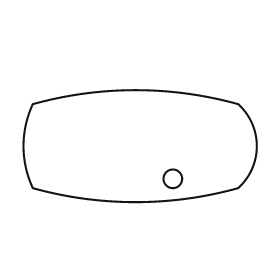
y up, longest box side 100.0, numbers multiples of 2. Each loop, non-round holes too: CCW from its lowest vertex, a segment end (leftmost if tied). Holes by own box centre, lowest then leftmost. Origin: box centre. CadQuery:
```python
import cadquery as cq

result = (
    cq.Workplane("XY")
    .moveTo(-46.0, -18.0)
    .threePointArc((-2.0, -24.0), (42.0, -18.0))
    .threePointArc((50.0, 0.0), (42.0, 18.0))
    .threePointArc((-2.0, 24.0), (-46.0, 18.0))
    .threePointArc((-50.0, 0.0), (-46.0, -18.0))
    .close()
    .moveTo(14.0, -14.0)
    .circle(4.0)
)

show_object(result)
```